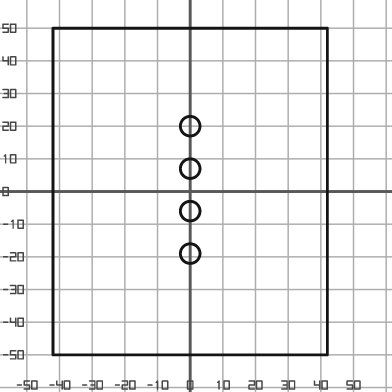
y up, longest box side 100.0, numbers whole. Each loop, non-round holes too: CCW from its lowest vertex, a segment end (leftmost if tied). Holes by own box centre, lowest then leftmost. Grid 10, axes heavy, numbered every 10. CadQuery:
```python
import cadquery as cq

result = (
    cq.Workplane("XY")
    .moveTo(-42.0, -50.0)
    .lineTo(42.0, -50.0)
    .lineTo(42.0, 50.0)
    .lineTo(-42.0, 50.0)
    .close()
    .moveTo(0.0, -19.0)
    .circle(3.0)
    .moveTo(0.0, -6.0)
    .circle(3.0)
    .moveTo(0.0, 7.0)
    .circle(3.0)
    .moveTo(0.0, 20.0)
    .circle(3.0)
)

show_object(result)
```